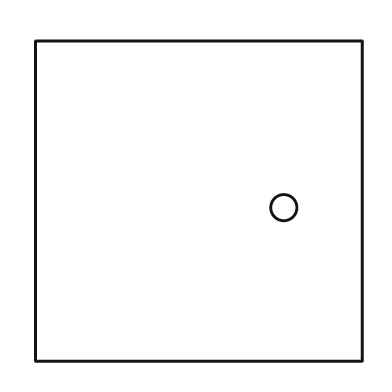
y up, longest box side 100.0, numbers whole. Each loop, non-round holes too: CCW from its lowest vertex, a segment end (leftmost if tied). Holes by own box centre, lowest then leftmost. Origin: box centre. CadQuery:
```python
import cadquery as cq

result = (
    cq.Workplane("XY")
    .moveTo(-50.0, -49.0)
    .lineTo(50.0, -49.0)
    .lineTo(50.0, 49.0)
    .lineTo(-50.0, 49.0)
    .close()
    .moveTo(26.0, -2.0)
    .circle(4.0)
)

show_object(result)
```